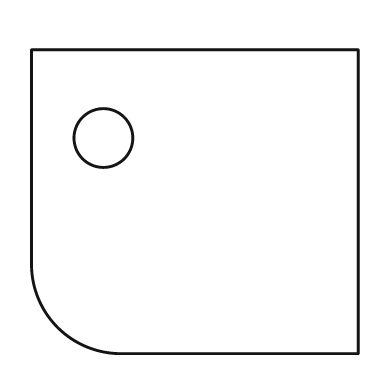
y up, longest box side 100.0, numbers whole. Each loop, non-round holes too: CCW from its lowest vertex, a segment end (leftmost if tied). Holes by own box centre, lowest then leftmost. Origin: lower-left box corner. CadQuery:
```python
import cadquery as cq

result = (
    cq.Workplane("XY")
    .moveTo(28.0, 0.0)
    .lineTo(100.0, 0.0)
    .lineTo(100.0, 93.0)
    .lineTo(0.0, 93.0)
    .lineTo(0.0, 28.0)
    .threePointArc((8.0, 8.0), (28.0, 0.0))
    .close()
    .moveTo(22.0, 66.0)
    .circle(9.0)
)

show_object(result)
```